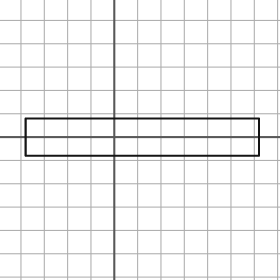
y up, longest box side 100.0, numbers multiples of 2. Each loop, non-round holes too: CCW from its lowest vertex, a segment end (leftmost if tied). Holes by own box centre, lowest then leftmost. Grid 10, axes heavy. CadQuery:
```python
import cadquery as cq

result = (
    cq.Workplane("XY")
    .moveTo(-38.0, -8.0)
    .lineTo(62.0, -8.0)
    .lineTo(62.0, 8.0)
    .lineTo(-38.0, 8.0)
    .close()
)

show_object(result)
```